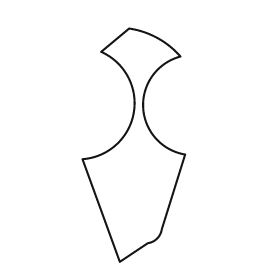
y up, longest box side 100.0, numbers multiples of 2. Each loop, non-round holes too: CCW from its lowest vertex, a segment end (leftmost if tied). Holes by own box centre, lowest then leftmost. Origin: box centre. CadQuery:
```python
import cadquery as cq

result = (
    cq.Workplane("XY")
    .moveTo(-6.0, -50.0)
    .lineTo(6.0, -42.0)
    .threePointArc((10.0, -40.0), (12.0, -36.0))
    .lineTo(22.0, -4.0)
    .threePointArc((4.0, 16.0), (20.0, 38.0))
    .threePointArc((10.0, 46.0), (-2.0, 50.0))
    .lineTo(-14.0, 40.0)
    .threePointArc((0.0, 14.0), (-22.0, -6.0))
    .close()
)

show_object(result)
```